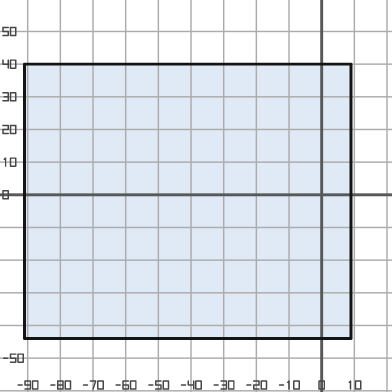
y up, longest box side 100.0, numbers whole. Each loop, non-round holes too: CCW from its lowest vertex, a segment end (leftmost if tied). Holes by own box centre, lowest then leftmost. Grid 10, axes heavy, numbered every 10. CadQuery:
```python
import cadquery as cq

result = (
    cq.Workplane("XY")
    .moveTo(-91.0, -44.0)
    .lineTo(9.0, -44.0)
    .lineTo(9.0, 40.0)
    .lineTo(-91.0, 40.0)
    .close()
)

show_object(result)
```